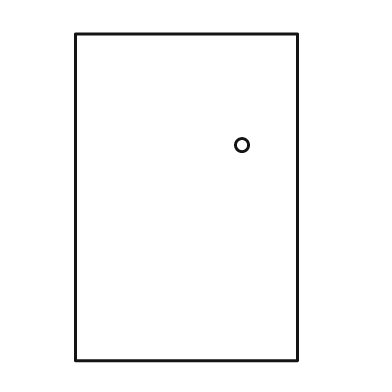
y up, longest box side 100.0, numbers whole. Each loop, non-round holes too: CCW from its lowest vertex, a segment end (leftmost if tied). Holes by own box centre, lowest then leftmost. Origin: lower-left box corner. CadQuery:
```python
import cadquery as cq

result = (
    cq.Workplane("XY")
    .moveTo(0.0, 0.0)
    .lineTo(68.0, 0.0)
    .lineTo(68.0, 100.0)
    .lineTo(0.0, 100.0)
    .close()
    .moveTo(51.0, 66.0)
    .circle(2.0)
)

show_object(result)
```